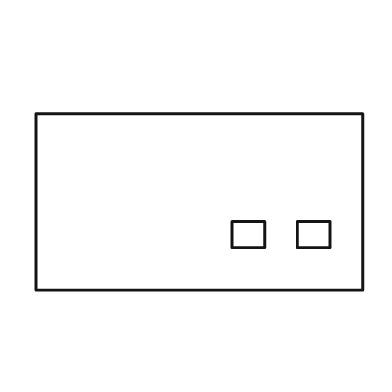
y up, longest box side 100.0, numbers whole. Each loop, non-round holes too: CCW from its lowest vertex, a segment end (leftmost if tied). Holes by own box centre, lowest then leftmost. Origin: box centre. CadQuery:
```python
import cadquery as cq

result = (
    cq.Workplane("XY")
    .moveTo(-50.0, -27.0)
    .lineTo(50.0, -27.0)
    .lineTo(50.0, 27.0)
    .lineTo(-50.0, 27.0)
    .close()
    .moveTo(10.0, -14.0)
    .lineTo(20.0, -14.0)
    .lineTo(20.0, -6.0)
    .lineTo(10.0, -6.0)
    .close()
    .moveTo(30.0, -14.0)
    .lineTo(40.0, -14.0)
    .lineTo(40.0, -6.0)
    .lineTo(30.0, -6.0)
    .close()
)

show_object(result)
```